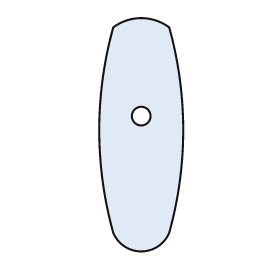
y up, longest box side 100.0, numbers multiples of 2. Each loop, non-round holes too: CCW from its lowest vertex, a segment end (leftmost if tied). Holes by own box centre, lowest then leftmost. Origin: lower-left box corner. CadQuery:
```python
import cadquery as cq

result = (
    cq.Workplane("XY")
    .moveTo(6.0, 8.0)
    .threePointArc((18.0, 0.0), (30.0, 8.0))
    .threePointArc((36.0, 52.0), (30.0, 96.0))
    .threePointArc((18.0, 100.0), (6.0, 96.0))
    .threePointArc((0.0, 52.0), (6.0, 8.0))
    .close()
    .moveTo(18.0, 58.0)
    .circle(4.0)
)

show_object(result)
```